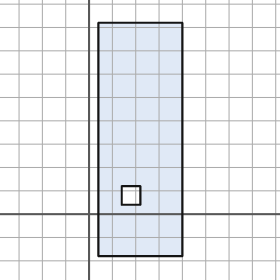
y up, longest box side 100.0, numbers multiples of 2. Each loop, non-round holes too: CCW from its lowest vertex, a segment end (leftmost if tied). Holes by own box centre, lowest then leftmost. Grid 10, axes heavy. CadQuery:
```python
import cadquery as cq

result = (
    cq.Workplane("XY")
    .moveTo(4.0, -18.0)
    .lineTo(40.0, -18.0)
    .lineTo(40.0, 82.0)
    .lineTo(4.0, 82.0)
    .close()
    .moveTo(14.0, 4.0)
    .lineTo(22.0, 4.0)
    .lineTo(22.0, 12.0)
    .lineTo(14.0, 12.0)
    .close()
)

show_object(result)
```